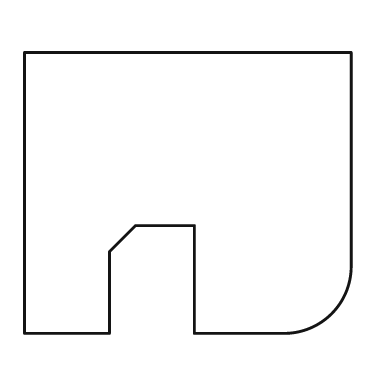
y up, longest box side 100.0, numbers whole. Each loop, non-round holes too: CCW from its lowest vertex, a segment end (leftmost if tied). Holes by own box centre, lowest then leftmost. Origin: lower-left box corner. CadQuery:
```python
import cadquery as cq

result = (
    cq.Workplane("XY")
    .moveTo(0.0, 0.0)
    .lineTo(26.0, 0.0)
    .lineTo(26.0, 25.0)
    .lineTo(34.0, 33.0)
    .lineTo(52.0, 33.0)
    .lineTo(52.0, 0.0)
    .lineTo(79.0, 0.0)
    .threePointArc((94.0, 6.0), (100.0, 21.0))
    .lineTo(100.0, 86.0)
    .lineTo(0.0, 86.0)
    .close()
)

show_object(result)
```